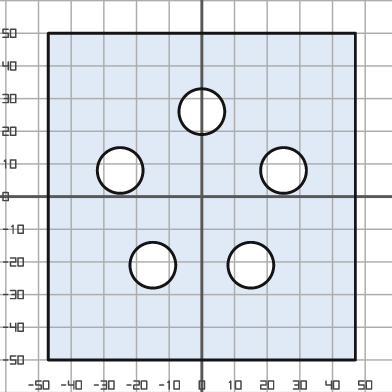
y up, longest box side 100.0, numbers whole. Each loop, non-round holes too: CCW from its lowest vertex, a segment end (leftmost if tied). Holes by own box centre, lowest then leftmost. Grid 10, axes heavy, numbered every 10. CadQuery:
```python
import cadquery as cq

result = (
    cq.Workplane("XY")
    .moveTo(-47.0, -50.0)
    .lineTo(47.0, -50.0)
    .lineTo(47.0, 50.0)
    .lineTo(-47.0, 50.0)
    .close()
    .moveTo(-15.0, -21.0)
    .circle(7.0)
    .moveTo(15.0, -21.0)
    .circle(7.0)
    .moveTo(-25.0, 8.0)
    .circle(7.0)
    .moveTo(25.0, 8.0)
    .circle(7.0)
    .moveTo(0.0, 26.0)
    .circle(7.0)
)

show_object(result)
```